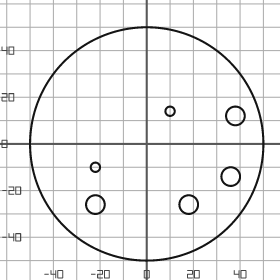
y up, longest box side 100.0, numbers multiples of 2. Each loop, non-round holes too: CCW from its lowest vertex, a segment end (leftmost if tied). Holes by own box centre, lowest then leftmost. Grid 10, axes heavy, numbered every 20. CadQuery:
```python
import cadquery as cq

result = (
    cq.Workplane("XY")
    .moveTo(0.0, 0.0)
    .circle(50.0)
    .moveTo(-22.0, -26.0)
    .circle(4.0)
    .moveTo(18.0, -26.0)
    .circle(4.0)
    .moveTo(36.0, -14.0)
    .circle(4.0)
    .moveTo(-22.0, -10.0)
    .circle(2.0)
    .moveTo(38.0, 12.0)
    .circle(4.0)
    .moveTo(10.0, 14.0)
    .circle(2.0)
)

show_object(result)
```